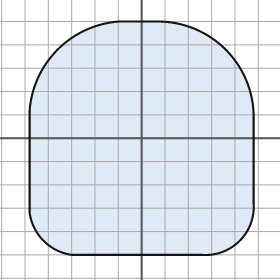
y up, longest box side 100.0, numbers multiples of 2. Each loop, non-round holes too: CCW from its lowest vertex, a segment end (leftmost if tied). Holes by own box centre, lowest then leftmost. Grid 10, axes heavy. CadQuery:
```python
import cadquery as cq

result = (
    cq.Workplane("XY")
    .moveTo(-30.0, -50.0)
    .lineTo(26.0, -50.0)
    .threePointArc((42.0, -44.0), (48.0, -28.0))
    .lineTo(48.0, 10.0)
    .threePointArc((36.0, 38.0), (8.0, 50.0))
    .lineTo(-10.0, 50.0)
    .threePointArc((-36.0, 38.0), (-48.0, 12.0))
    .lineTo(-48.0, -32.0)
    .threePointArc((-42.0, -44.0), (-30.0, -50.0))
    .close()
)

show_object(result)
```